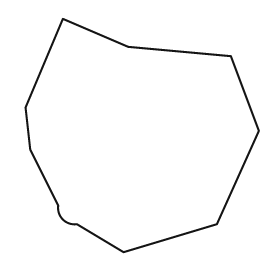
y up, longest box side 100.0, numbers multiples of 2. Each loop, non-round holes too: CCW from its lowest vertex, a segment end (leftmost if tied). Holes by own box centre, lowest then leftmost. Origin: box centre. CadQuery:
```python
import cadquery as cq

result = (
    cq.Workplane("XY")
    .moveTo(-8.0, -50.0)
    .lineTo(32.0, -38.0)
    .lineTo(50.0, 2.0)
    .lineTo(38.0, 34.0)
    .lineTo(-6.0, 38.0)
    .lineTo(-34.0, 50.0)
    .lineTo(-50.0, 12.0)
    .lineTo(-48.0, -6.0)
    .lineTo(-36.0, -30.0)
    .threePointArc((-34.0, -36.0), (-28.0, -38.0))
    .close()
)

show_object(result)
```